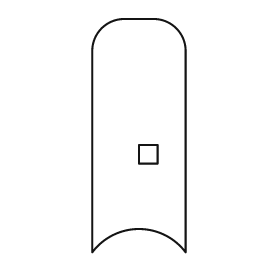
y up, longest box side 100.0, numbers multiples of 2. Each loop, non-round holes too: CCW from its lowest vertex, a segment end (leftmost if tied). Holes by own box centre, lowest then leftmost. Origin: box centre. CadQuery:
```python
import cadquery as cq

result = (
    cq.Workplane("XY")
    .moveTo(-20.0, -50.0)
    .threePointArc((0.0, -40.0), (20.0, -50.0))
    .lineTo(20.0, 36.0)
    .threePointArc((16.0, 46.0), (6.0, 50.0))
    .lineTo(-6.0, 50.0)
    .threePointArc((-16.0, 46.0), (-20.0, 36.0))
    .close()
    .moveTo(0.0, -12.0)
    .lineTo(8.0, -12.0)
    .lineTo(8.0, -4.0)
    .lineTo(0.0, -4.0)
    .close()
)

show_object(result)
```